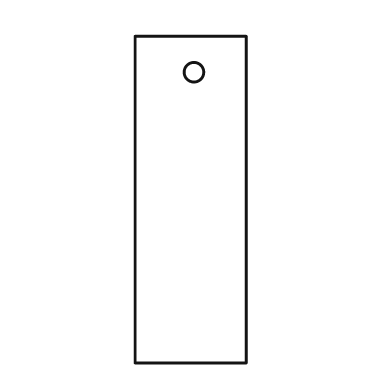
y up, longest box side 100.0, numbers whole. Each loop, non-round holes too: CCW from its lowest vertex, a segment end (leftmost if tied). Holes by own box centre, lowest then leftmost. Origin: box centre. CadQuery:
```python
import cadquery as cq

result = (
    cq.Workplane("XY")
    .moveTo(-17.0, -50.0)
    .lineTo(17.0, -50.0)
    .lineTo(17.0, 50.0)
    .lineTo(-17.0, 50.0)
    .close()
    .moveTo(1.0, 39.0)
    .circle(3.0)
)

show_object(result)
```